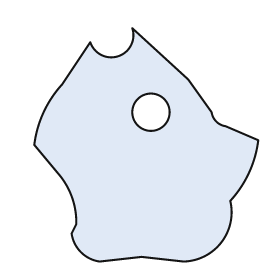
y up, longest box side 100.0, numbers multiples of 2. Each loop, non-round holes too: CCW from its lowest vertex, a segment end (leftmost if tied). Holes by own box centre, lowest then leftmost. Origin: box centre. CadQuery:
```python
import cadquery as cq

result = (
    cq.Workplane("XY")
    .moveTo(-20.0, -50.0)
    .lineTo(-2.0, -48.0)
    .lineTo(16.0, -50.0)
    .threePointArc((32.0, -42.0), (36.0, -24.0))
    .threePointArc((44.0, -12.0), (48.0, 2.0))
    .lineTo(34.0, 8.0)
    .threePointArc((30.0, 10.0), (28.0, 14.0))
    .lineTo(18.0, 28.0)
    .lineTo(-6.0, 50.0)
    .threePointArc((-12.0, 38.0), (-24.0, 44.0))
    .lineTo(-36.0, 26.0)
    .threePointArc((-44.0, 14.0), (-48.0, 0.0))
    .lineTo(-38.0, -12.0)
    .threePointArc((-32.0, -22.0), (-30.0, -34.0))
    .lineTo(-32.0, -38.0)
    .threePointArc((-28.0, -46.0), (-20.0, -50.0))
    .close()
    .moveTo(2.0, 14.0)
    .circle(8.0)
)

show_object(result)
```